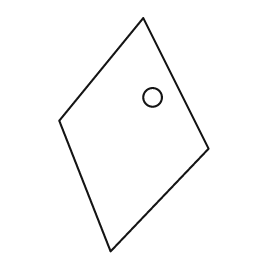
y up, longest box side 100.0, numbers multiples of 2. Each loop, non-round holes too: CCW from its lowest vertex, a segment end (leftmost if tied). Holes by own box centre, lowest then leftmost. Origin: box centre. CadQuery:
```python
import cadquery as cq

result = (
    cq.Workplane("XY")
    .moveTo(-10.0, -50.0)
    .lineTo(32.0, -6.0)
    .lineTo(4.0, 50.0)
    .lineTo(-32.0, 6.0)
    .close()
    .moveTo(8.0, 16.0)
    .circle(4.0)
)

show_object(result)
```